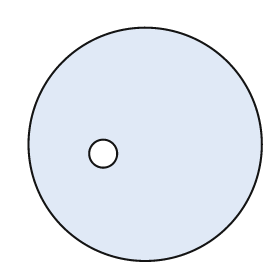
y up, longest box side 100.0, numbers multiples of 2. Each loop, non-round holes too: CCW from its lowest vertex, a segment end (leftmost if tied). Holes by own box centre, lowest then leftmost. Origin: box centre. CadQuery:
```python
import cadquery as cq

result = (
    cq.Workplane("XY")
    .moveTo(0.0, 0.0)
    .circle(50.0)
    .moveTo(-18.0, -4.0)
    .circle(6.0)
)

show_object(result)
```